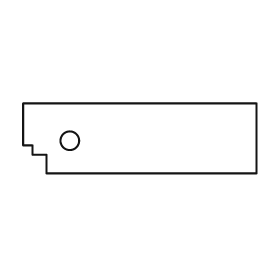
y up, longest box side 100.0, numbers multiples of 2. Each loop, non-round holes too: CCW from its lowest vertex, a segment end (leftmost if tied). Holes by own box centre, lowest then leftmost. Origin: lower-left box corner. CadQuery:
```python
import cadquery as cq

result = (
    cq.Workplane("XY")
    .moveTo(10.0, 0.0)
    .lineTo(100.0, 0.0)
    .lineTo(100.0, 30.0)
    .lineTo(0.0, 30.0)
    .lineTo(0.0, 12.0)
    .lineTo(4.0, 12.0)
    .lineTo(4.0, 8.0)
    .lineTo(10.0, 8.0)
    .close()
    .moveTo(20.0, 14.0)
    .circle(4.0)
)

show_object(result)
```